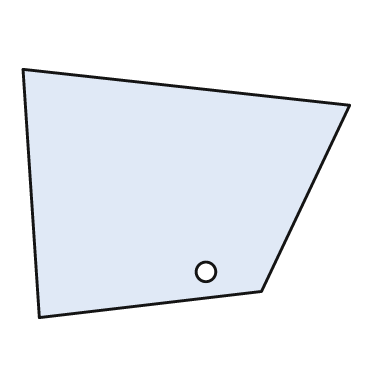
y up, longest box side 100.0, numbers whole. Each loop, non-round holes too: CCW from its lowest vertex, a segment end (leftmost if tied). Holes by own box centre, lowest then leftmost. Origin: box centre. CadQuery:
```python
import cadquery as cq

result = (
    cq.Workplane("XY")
    .moveTo(-45.0, -38.0)
    .lineTo(23.0, -30.0)
    .lineTo(50.0, 27.0)
    .lineTo(-50.0, 38.0)
    .close()
    .moveTo(6.0, -24.0)
    .circle(3.0)
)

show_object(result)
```